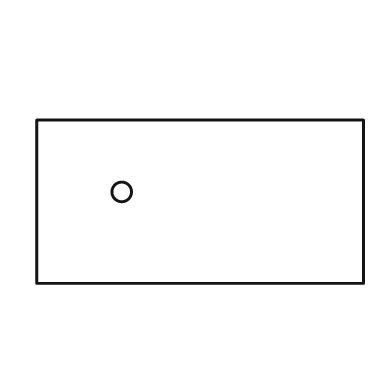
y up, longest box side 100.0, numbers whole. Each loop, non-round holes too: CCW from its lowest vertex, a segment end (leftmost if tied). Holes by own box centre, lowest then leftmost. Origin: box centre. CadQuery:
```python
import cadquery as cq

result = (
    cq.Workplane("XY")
    .moveTo(-50.0, -25.0)
    .lineTo(50.0, -25.0)
    .lineTo(50.0, 25.0)
    .lineTo(-50.0, 25.0)
    .close()
    .moveTo(-24.0, 3.0)
    .circle(3.0)
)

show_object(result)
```